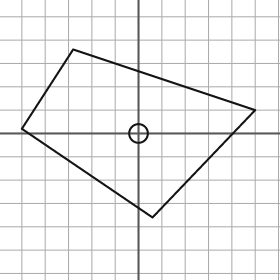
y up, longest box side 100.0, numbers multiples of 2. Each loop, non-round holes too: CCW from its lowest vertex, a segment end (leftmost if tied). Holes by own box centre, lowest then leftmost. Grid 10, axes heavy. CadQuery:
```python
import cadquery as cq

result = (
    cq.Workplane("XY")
    .moveTo(6.0, -36.0)
    .lineTo(50.0, 10.0)
    .lineTo(-28.0, 36.0)
    .lineTo(-50.0, 2.0)
    .close()
    .moveTo(0.0, 0.0)
    .circle(4.0)
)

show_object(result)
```